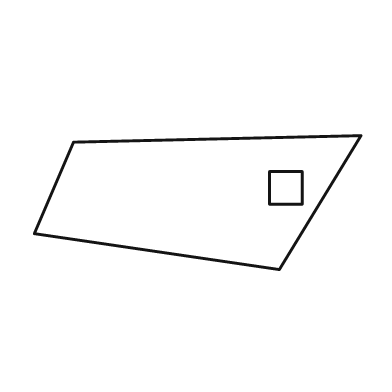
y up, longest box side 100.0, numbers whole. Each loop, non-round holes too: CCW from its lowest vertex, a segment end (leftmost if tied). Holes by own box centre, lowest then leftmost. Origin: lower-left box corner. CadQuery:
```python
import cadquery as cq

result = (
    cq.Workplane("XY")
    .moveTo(75.0, 0.0)
    .lineTo(100.0, 41.0)
    .lineTo(12.0, 39.0)
    .lineTo(0.0, 11.0)
    .close()
    .moveTo(72.0, 20.0)
    .lineTo(82.0, 20.0)
    .lineTo(82.0, 30.0)
    .lineTo(72.0, 30.0)
    .close()
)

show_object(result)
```